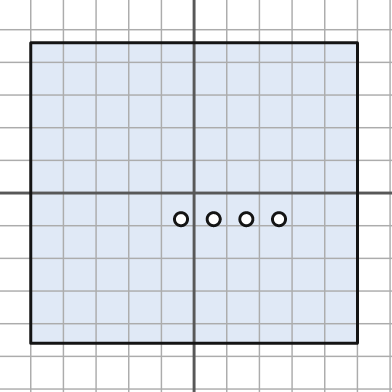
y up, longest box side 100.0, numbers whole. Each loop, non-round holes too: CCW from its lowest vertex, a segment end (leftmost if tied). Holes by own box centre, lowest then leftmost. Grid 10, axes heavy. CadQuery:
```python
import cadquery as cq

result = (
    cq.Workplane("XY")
    .moveTo(-50.0, -46.0)
    .lineTo(50.0, -46.0)
    .lineTo(50.0, 46.0)
    .lineTo(-50.0, 46.0)
    .close()
    .moveTo(-4.0, -8.0)
    .circle(2.0)
    .moveTo(6.0, -8.0)
    .circle(2.0)
    .moveTo(16.0, -8.0)
    .circle(2.0)
    .moveTo(26.0, -8.0)
    .circle(2.0)
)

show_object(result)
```